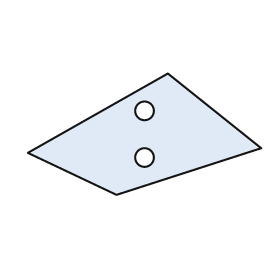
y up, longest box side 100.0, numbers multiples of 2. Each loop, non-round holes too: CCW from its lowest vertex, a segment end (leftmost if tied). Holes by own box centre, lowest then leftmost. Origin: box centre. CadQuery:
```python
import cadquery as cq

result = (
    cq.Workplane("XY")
    .moveTo(-12.0, -26.0)
    .lineTo(50.0, -6.0)
    .lineTo(10.0, 26.0)
    .lineTo(-50.0, -8.0)
    .close()
    .moveTo(0.0, -10.0)
    .circle(4.0)
    .moveTo(0.0, 10.0)
    .circle(4.0)
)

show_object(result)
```